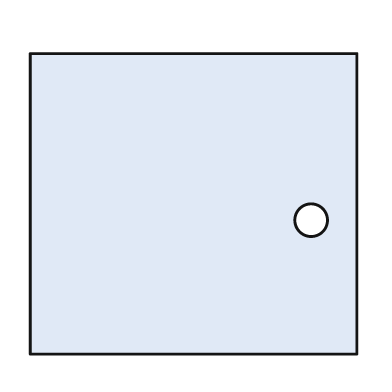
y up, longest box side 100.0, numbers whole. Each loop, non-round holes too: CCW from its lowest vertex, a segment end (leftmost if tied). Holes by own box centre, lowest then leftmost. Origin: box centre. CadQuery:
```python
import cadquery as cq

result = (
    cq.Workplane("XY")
    .moveTo(-50.0, -46.0)
    .lineTo(50.0, -46.0)
    .lineTo(50.0, 46.0)
    .lineTo(-50.0, 46.0)
    .close()
    .moveTo(36.0, -5.0)
    .circle(5.0)
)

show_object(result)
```